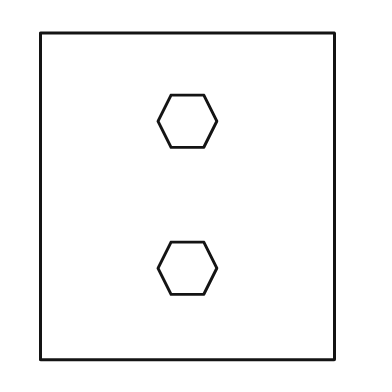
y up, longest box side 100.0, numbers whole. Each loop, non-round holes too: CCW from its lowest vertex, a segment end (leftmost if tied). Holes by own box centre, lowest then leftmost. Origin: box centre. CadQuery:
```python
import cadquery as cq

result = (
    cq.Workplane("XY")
    .moveTo(-45.0, -50.0)
    .lineTo(45.0, -50.0)
    .lineTo(45.0, 50.0)
    .lineTo(-45.0, 50.0)
    .close()
    .moveTo(-5.0, -30.0)
    .lineTo(5.0, -30.0)
    .lineTo(9.0, -22.0)
    .lineTo(5.0, -14.0)
    .lineTo(-5.0, -14.0)
    .lineTo(-9.0, -22.0)
    .close()
    .moveTo(-5.0, 15.0)
    .lineTo(5.0, 15.0)
    .lineTo(9.0, 23.0)
    .lineTo(5.0, 31.0)
    .lineTo(-5.0, 31.0)
    .lineTo(-9.0, 23.0)
    .close()
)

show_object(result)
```